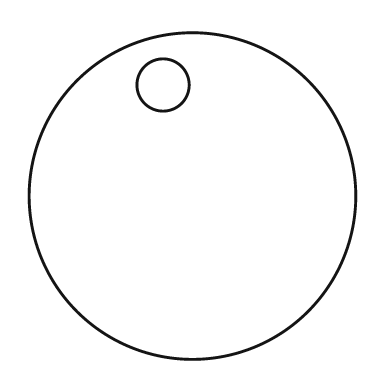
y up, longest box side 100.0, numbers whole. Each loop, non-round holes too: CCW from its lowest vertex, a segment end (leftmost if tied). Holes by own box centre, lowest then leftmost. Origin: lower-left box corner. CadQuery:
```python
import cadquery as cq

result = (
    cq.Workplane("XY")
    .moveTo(50.0, 50.0)
    .circle(50.0)
    .moveTo(41.0, 84.0)
    .circle(8.0)
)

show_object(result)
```